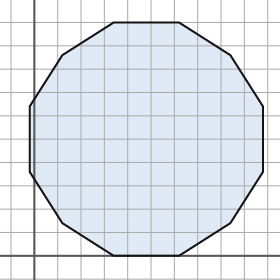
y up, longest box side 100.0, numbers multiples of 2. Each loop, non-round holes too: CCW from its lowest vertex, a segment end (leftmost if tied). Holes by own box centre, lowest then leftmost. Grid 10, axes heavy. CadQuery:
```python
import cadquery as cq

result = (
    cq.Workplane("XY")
    .moveTo(34.0, 0.0)
    .lineTo(62.0, 0.0)
    .lineTo(84.0, 14.0)
    .lineTo(98.0, 36.0)
    .lineTo(98.0, 64.0)
    .lineTo(84.0, 86.0)
    .lineTo(62.0, 100.0)
    .lineTo(34.0, 100.0)
    .lineTo(12.0, 86.0)
    .lineTo(-2.0, 64.0)
    .lineTo(-2.0, 36.0)
    .lineTo(12.0, 14.0)
    .close()
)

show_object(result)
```